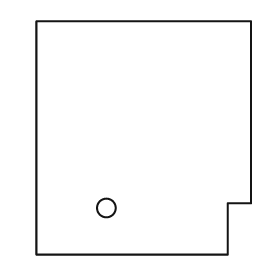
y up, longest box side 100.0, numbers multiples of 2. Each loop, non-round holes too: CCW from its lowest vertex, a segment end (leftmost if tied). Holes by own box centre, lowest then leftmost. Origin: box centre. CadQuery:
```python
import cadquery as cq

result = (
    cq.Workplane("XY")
    .moveTo(-46.0, -50.0)
    .lineTo(36.0, -50.0)
    .lineTo(36.0, -28.0)
    .lineTo(46.0, -28.0)
    .lineTo(46.0, 50.0)
    .lineTo(-46.0, 50.0)
    .close()
    .moveTo(-16.0, -30.0)
    .circle(4.0)
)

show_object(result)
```